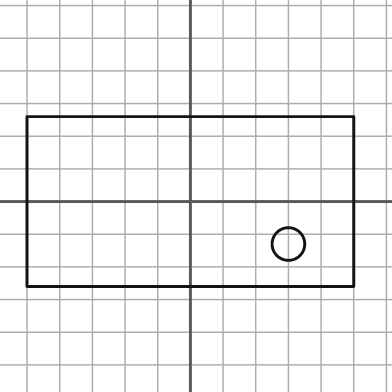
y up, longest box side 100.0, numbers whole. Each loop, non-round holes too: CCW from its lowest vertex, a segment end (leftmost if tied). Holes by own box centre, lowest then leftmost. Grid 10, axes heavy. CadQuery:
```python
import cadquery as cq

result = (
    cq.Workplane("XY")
    .moveTo(-50.0, -26.0)
    .lineTo(50.0, -26.0)
    .lineTo(50.0, 26.0)
    .lineTo(-50.0, 26.0)
    .close()
    .moveTo(30.0, -13.0)
    .circle(5.0)
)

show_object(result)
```